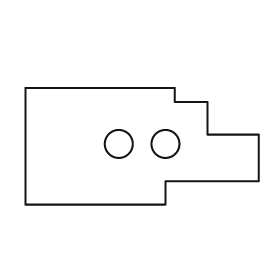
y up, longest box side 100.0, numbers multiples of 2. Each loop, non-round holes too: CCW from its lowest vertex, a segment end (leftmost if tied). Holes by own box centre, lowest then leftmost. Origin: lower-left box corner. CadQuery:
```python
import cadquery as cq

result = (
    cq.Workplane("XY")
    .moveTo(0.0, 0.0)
    .lineTo(60.0, 0.0)
    .lineTo(60.0, 10.0)
    .lineTo(100.0, 10.0)
    .lineTo(100.0, 30.0)
    .lineTo(78.0, 30.0)
    .lineTo(78.0, 44.0)
    .lineTo(64.0, 44.0)
    .lineTo(64.0, 50.0)
    .lineTo(0.0, 50.0)
    .close()
    .moveTo(40.0, 26.0)
    .circle(6.0)
    .moveTo(60.0, 26.0)
    .circle(6.0)
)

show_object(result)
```